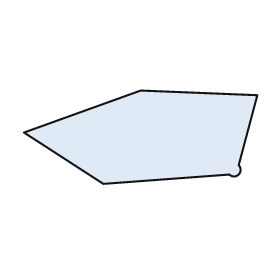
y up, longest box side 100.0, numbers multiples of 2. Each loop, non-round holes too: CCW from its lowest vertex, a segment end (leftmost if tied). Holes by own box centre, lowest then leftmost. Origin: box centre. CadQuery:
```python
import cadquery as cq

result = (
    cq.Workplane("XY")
    .moveTo(-16.0, -20.0)
    .lineTo(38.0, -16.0)
    .threePointArc((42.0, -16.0), (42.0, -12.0))
    .lineTo(50.0, 18.0)
    .lineTo(0.0, 20.0)
    .lineTo(-50.0, 2.0)
    .close()
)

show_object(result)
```